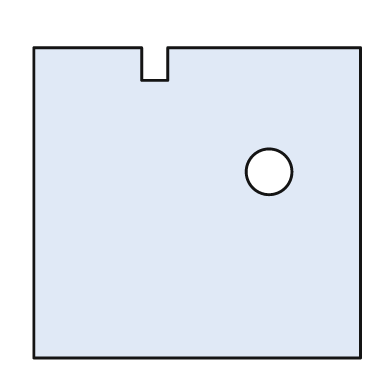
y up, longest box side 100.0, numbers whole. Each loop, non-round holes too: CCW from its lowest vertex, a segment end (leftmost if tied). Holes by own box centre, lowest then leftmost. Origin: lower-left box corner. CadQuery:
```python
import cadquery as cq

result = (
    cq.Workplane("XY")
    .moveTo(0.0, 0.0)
    .lineTo(100.0, 0.0)
    .lineTo(100.0, 95.0)
    .lineTo(41.0, 95.0)
    .lineTo(41.0, 85.0)
    .lineTo(33.0, 85.0)
    .lineTo(33.0, 95.0)
    .lineTo(0.0, 95.0)
    .close()
    .moveTo(72.0, 57.0)
    .circle(7.0)
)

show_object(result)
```